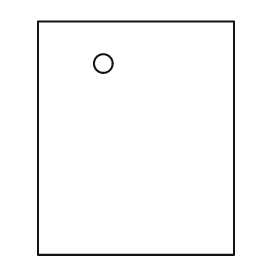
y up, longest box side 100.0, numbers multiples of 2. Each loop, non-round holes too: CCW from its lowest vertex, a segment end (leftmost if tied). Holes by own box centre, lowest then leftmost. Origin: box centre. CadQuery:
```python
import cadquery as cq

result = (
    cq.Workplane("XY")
    .moveTo(-42.0, -50.0)
    .lineTo(42.0, -50.0)
    .lineTo(42.0, 50.0)
    .lineTo(-42.0, 50.0)
    .close()
    .moveTo(-14.0, 32.0)
    .circle(4.0)
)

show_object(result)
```